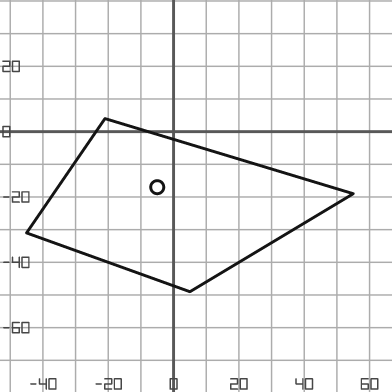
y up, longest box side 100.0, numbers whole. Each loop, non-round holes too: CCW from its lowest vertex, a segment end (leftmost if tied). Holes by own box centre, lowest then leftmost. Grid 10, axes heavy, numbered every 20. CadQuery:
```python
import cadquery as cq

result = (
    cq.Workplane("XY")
    .moveTo(5.0, -49.0)
    .lineTo(55.0, -19.0)
    .lineTo(-21.0, 4.0)
    .lineTo(-45.0, -31.0)
    .close()
    .moveTo(-5.0, -17.0)
    .circle(2.0)
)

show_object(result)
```